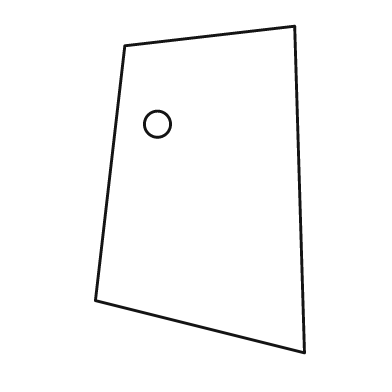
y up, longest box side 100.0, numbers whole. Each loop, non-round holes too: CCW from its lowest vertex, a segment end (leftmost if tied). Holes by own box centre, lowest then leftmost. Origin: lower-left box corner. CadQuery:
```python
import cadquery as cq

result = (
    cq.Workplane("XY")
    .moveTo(64.0, 0.0)
    .lineTo(61.0, 100.0)
    .lineTo(9.0, 94.0)
    .lineTo(0.0, 16.0)
    .close()
    .moveTo(19.0, 70.0)
    .circle(4.0)
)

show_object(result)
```